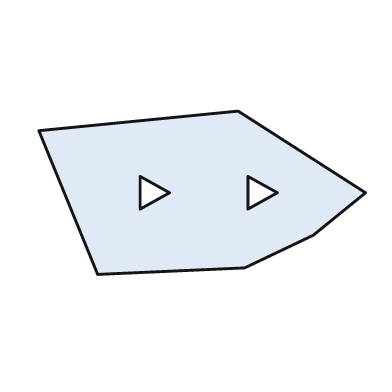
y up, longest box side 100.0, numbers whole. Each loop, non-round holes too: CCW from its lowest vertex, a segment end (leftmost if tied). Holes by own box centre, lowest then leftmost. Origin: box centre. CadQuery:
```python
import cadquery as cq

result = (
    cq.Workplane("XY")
    .moveTo(-32.0, -25.0)
    .lineTo(13.0, -23.0)
    .lineTo(34.0, -13.0)
    .lineTo(50.0, 0.0)
    .lineTo(11.0, 25.0)
    .lineTo(-50.0, 19.0)
    .close()
    .moveTo(-19.0, -5.0)
    .lineTo(-10.0, 0.0)
    .lineTo(-19.0, 5.0)
    .close()
    .moveTo(14.0, -5.0)
    .lineTo(23.0, 0.0)
    .lineTo(14.0, 5.0)
    .close()
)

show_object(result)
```